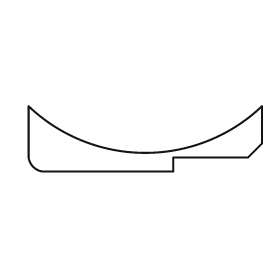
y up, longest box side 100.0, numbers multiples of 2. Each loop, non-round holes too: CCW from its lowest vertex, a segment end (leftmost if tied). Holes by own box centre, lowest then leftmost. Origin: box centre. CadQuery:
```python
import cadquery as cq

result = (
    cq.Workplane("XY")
    .moveTo(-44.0, -14.0)
    .lineTo(12.0, -14.0)
    .lineTo(12.0, -8.0)
    .lineTo(44.0, -8.0)
    .lineTo(50.0, -2.0)
    .lineTo(50.0, 14.0)
    .threePointArc((0.0, -6.0), (-50.0, 14.0))
    .lineTo(-50.0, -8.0)
    .threePointArc((-48.0, -12.0), (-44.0, -14.0))
    .close()
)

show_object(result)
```